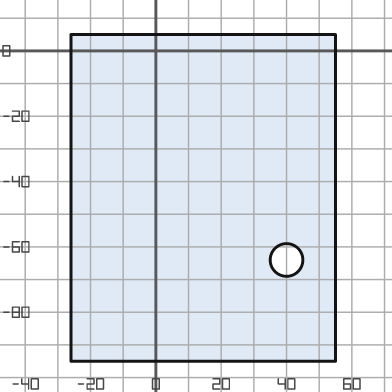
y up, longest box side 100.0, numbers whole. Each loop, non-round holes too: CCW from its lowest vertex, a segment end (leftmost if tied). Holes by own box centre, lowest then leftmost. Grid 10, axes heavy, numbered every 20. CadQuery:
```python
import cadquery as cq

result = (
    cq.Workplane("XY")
    .moveTo(-26.0, -95.0)
    .lineTo(55.0, -95.0)
    .lineTo(55.0, 5.0)
    .lineTo(-26.0, 5.0)
    .close()
    .moveTo(40.0, -64.0)
    .circle(5.0)
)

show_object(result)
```